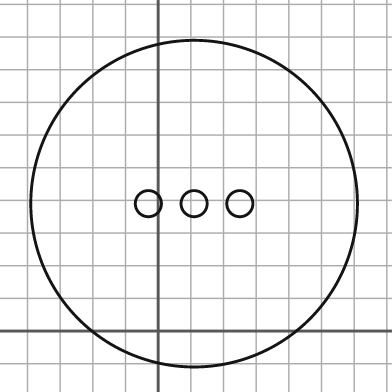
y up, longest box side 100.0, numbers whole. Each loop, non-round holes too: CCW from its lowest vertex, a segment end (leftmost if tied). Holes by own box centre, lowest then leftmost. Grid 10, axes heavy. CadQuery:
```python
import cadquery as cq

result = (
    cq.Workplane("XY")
    .moveTo(11.0, 39.0)
    .circle(50.0)
    .moveTo(-3.0, 39.0)
    .circle(4.0)
    .moveTo(11.0, 39.0)
    .circle(4.0)
    .moveTo(25.0, 39.0)
    .circle(4.0)
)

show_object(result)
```